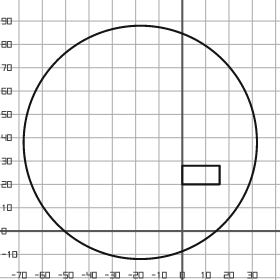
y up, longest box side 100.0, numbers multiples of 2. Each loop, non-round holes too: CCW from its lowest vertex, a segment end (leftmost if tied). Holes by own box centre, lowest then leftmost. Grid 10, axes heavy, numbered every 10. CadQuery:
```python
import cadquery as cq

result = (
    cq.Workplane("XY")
    .moveTo(-18.0, 38.0)
    .circle(50.0)
    .moveTo(0.0, 20.0)
    .lineTo(16.0, 20.0)
    .lineTo(16.0, 28.0)
    .lineTo(0.0, 28.0)
    .close()
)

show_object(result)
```